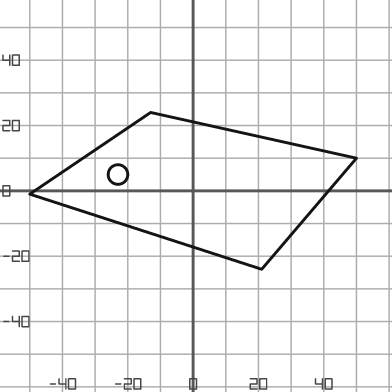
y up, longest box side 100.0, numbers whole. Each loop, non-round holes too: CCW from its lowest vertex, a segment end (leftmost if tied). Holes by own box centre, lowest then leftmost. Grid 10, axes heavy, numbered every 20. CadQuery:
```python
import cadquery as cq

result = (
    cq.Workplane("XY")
    .moveTo(21.0, -24.0)
    .lineTo(50.0, 10.0)
    .lineTo(-13.0, 24.0)
    .lineTo(-50.0, -1.0)
    .close()
    .moveTo(-23.0, 5.0)
    .circle(3.0)
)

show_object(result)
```